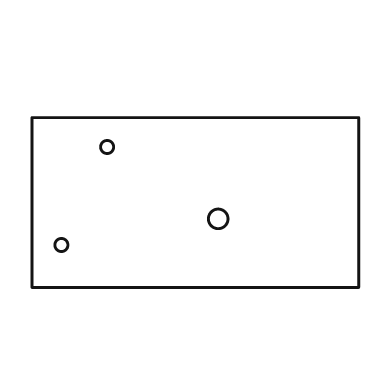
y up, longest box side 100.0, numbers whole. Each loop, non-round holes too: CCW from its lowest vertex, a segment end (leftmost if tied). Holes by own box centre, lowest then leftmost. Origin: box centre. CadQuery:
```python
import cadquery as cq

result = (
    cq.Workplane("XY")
    .moveTo(-50.0, -26.0)
    .lineTo(50.0, -26.0)
    .lineTo(50.0, 26.0)
    .lineTo(-50.0, 26.0)
    .close()
    .moveTo(-41.0, -13.0)
    .circle(2.0)
    .moveTo(7.0, -5.0)
    .circle(3.0)
    .moveTo(-27.0, 17.0)
    .circle(2.0)
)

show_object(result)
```